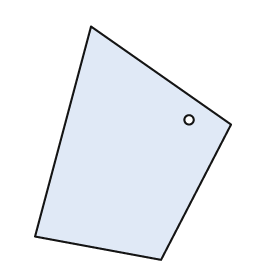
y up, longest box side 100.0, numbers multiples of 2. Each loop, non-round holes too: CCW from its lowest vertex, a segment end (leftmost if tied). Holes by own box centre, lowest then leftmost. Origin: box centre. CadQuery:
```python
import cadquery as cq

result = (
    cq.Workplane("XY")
    .moveTo(12.0, -50.0)
    .lineTo(42.0, 8.0)
    .lineTo(-18.0, 50.0)
    .lineTo(-42.0, -40.0)
    .close()
    .moveTo(24.0, 10.0)
    .circle(2.0)
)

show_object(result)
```